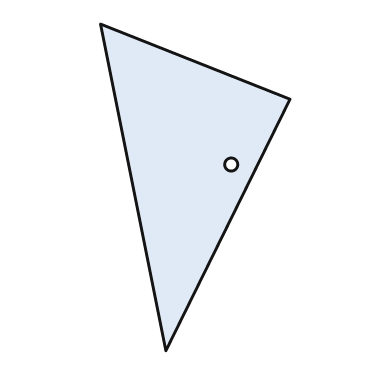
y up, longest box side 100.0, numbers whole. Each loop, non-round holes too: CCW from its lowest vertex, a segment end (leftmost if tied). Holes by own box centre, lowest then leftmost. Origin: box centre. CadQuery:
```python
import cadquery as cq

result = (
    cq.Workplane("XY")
    .moveTo(-9.0, -50.0)
    .lineTo(29.0, 27.0)
    .lineTo(-29.0, 50.0)
    .close()
    .moveTo(11.0, 7.0)
    .circle(2.0)
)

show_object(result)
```